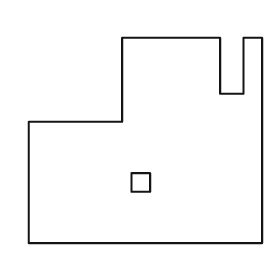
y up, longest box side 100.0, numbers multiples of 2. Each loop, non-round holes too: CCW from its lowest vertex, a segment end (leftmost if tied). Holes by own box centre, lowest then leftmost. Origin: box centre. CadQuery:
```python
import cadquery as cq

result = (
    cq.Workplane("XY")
    .moveTo(-50.0, -44.0)
    .lineTo(50.0, -44.0)
    .lineTo(50.0, 44.0)
    .lineTo(42.0, 44.0)
    .lineTo(42.0, 20.0)
    .lineTo(32.0, 20.0)
    .lineTo(32.0, 44.0)
    .lineTo(-10.0, 44.0)
    .lineTo(-10.0, 8.0)
    .lineTo(-50.0, 8.0)
    .close()
    .moveTo(-6.0, -22.0)
    .lineTo(2.0, -22.0)
    .lineTo(2.0, -14.0)
    .lineTo(-6.0, -14.0)
    .close()
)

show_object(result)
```